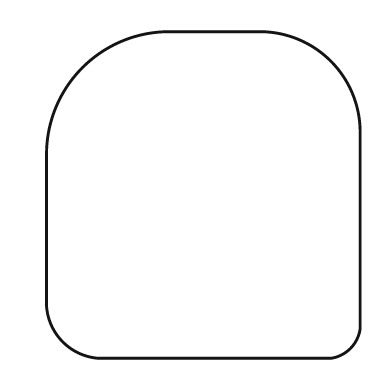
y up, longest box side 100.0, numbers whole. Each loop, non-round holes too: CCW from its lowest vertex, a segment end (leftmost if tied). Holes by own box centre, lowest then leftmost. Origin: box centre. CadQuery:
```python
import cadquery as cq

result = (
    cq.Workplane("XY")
    .moveTo(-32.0, -50.0)
    .lineTo(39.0, -50.0)
    .threePointArc((45.0, -47.0), (48.0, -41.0))
    .lineTo(48.0, 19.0)
    .threePointArc((39.0, 41.0), (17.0, 50.0))
    .lineTo(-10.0, 50.0)
    .threePointArc((-37.0, 39.0), (-48.0, 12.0))
    .lineTo(-48.0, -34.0)
    .threePointArc((-43.0, -45.0), (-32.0, -50.0))
    .close()
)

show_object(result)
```